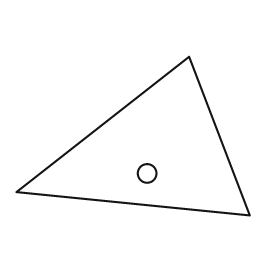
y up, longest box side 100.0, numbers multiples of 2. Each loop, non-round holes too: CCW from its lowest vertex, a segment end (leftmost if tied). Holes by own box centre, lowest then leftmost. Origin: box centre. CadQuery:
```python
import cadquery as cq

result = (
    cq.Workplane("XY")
    .moveTo(50.0, -34.0)
    .lineTo(24.0, 34.0)
    .lineTo(-50.0, -24.0)
    .close()
    .moveTo(6.0, -16.0)
    .circle(4.0)
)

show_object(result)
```